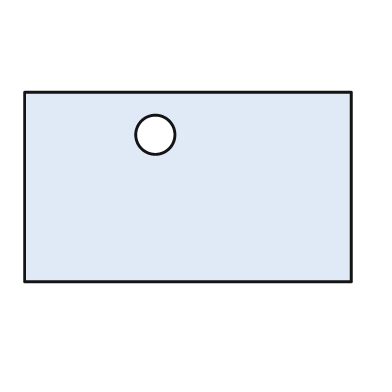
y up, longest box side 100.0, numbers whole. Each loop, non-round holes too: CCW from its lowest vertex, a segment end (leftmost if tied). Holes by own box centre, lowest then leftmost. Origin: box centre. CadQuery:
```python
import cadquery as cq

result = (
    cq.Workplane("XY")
    .moveTo(-50.0, -29.0)
    .lineTo(50.0, -29.0)
    .lineTo(50.0, 29.0)
    .lineTo(-50.0, 29.0)
    .close()
    .moveTo(-10.0, 16.0)
    .circle(6.0)
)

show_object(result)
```